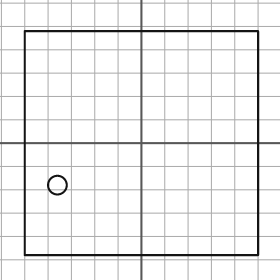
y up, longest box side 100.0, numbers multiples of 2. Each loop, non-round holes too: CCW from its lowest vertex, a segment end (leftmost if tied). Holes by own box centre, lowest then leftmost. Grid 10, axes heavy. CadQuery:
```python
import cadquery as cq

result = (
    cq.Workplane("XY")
    .moveTo(-50.0, -48.0)
    .lineTo(50.0, -48.0)
    .lineTo(50.0, 48.0)
    .lineTo(-50.0, 48.0)
    .close()
    .moveTo(-36.0, -18.0)
    .circle(4.0)
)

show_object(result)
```